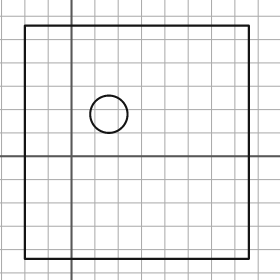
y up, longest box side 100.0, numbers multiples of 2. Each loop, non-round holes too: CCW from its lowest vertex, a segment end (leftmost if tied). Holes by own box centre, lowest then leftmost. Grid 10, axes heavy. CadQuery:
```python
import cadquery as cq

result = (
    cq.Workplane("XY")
    .moveTo(-20.0, -44.0)
    .lineTo(76.0, -44.0)
    .lineTo(76.0, 56.0)
    .lineTo(-20.0, 56.0)
    .close()
    .moveTo(16.0, 18.0)
    .circle(8.0)
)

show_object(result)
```